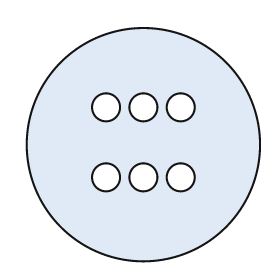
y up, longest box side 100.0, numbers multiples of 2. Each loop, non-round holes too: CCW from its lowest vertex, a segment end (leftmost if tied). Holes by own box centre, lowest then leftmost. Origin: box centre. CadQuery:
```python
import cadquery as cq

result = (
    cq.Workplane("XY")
    .moveTo(0.0, 0.0)
    .circle(50.0)
    .moveTo(-16.0, -14.0)
    .circle(6.0)
    .moveTo(0.0, -14.0)
    .circle(6.0)
    .moveTo(16.0, -14.0)
    .circle(6.0)
    .moveTo(-16.0, 16.0)
    .circle(6.0)
    .moveTo(0.0, 16.0)
    .circle(6.0)
    .moveTo(16.0, 16.0)
    .circle(6.0)
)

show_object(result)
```